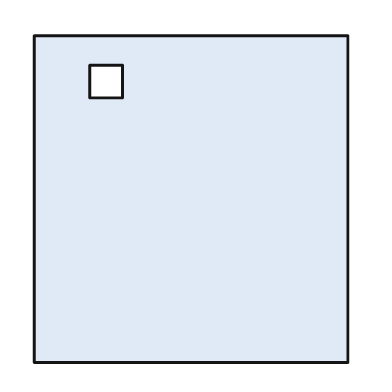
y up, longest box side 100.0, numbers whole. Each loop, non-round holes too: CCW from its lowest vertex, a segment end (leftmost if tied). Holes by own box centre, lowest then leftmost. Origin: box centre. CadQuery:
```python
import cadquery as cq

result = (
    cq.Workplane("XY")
    .moveTo(-48.0, -50.0)
    .lineTo(48.0, -50.0)
    .lineTo(48.0, 50.0)
    .lineTo(-48.0, 50.0)
    .close()
    .moveTo(-31.0, 31.0)
    .lineTo(-21.0, 31.0)
    .lineTo(-21.0, 41.0)
    .lineTo(-31.0, 41.0)
    .close()
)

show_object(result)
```